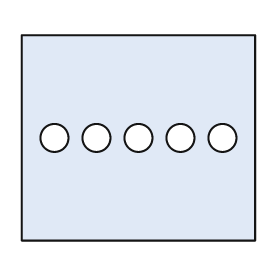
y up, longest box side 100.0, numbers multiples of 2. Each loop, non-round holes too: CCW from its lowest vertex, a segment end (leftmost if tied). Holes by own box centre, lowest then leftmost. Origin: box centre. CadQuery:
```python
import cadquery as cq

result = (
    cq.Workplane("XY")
    .moveTo(-50.0, -44.0)
    .lineTo(50.0, -44.0)
    .lineTo(50.0, 44.0)
    .lineTo(-50.0, 44.0)
    .close()
    .moveTo(-36.0, 0.0)
    .circle(6.0)
    .moveTo(-18.0, 0.0)
    .circle(6.0)
    .moveTo(0.0, 0.0)
    .circle(6.0)
    .moveTo(18.0, 0.0)
    .circle(6.0)
    .moveTo(36.0, 0.0)
    .circle(6.0)
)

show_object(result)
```